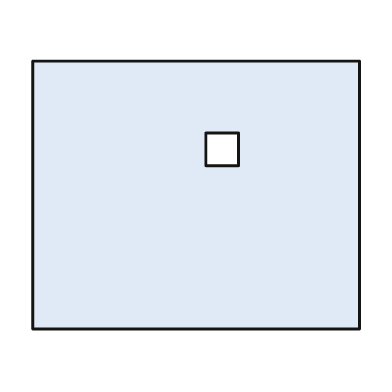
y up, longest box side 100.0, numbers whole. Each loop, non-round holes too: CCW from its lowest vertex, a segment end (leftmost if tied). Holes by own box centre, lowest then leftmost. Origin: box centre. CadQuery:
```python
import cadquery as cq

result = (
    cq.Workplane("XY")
    .moveTo(-50.0, -41.0)
    .lineTo(50.0, -41.0)
    .lineTo(50.0, 41.0)
    .lineTo(-50.0, 41.0)
    .close()
    .moveTo(3.0, 9.0)
    .lineTo(13.0, 9.0)
    .lineTo(13.0, 19.0)
    .lineTo(3.0, 19.0)
    .close()
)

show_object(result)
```